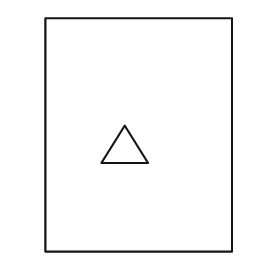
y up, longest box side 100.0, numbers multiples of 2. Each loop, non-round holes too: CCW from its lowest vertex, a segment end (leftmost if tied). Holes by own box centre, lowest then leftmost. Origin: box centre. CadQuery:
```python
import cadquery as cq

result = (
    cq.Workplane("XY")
    .moveTo(-40.0, -50.0)
    .lineTo(40.0, -50.0)
    .lineTo(40.0, 50.0)
    .lineTo(-40.0, 50.0)
    .close()
    .moveTo(-16.0, -12.0)
    .lineTo(4.0, -12.0)
    .lineTo(-6.0, 4.0)
    .close()
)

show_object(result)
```